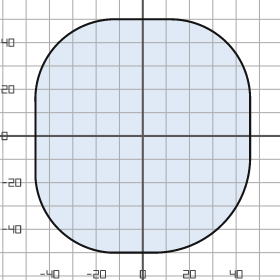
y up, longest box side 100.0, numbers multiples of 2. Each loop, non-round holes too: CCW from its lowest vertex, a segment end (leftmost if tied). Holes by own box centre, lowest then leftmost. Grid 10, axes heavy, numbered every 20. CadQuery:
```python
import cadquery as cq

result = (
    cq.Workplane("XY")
    .moveTo(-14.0, -50.0)
    .lineTo(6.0, -50.0)
    .threePointArc((34.0, -38.0), (46.0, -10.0))
    .lineTo(46.0, 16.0)
    .threePointArc((36.0, 40.0), (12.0, 50.0))
    .lineTo(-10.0, 50.0)
    .threePointArc((-36.0, 40.0), (-46.0, 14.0))
    .lineTo(-46.0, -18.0)
    .threePointArc((-36.0, -40.0), (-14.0, -50.0))
    .close()
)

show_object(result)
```